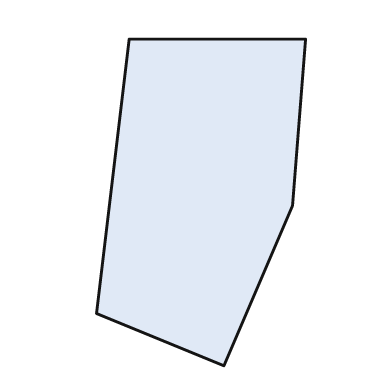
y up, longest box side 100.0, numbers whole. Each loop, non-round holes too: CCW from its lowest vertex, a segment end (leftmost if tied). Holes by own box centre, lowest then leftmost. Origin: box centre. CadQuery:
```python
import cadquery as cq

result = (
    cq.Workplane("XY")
    .moveTo(7.0, -50.0)
    .lineTo(28.0, -1.0)
    .lineTo(32.0, 50.0)
    .lineTo(-22.0, 50.0)
    .lineTo(-32.0, -34.0)
    .close()
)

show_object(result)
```